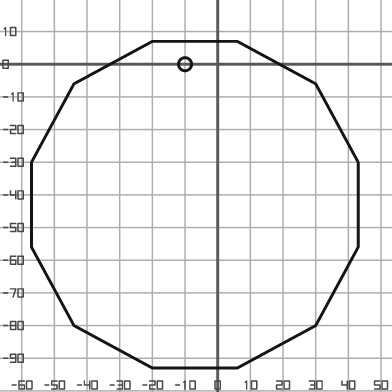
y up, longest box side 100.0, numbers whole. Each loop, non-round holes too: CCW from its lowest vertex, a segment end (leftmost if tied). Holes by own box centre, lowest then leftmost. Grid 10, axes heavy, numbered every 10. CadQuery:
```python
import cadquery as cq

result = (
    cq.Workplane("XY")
    .moveTo(-20.0, -93.0)
    .lineTo(6.0, -93.0)
    .lineTo(30.0, -80.0)
    .lineTo(43.0, -56.0)
    .lineTo(43.0, -30.0)
    .lineTo(30.0, -6.0)
    .lineTo(6.0, 7.0)
    .lineTo(-20.0, 7.0)
    .lineTo(-44.0, -6.0)
    .lineTo(-57.0, -30.0)
    .lineTo(-57.0, -56.0)
    .lineTo(-44.0, -80.0)
    .close()
    .moveTo(-10.0, 0.0)
    .circle(2.0)
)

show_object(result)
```